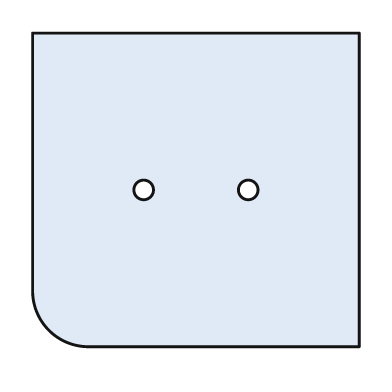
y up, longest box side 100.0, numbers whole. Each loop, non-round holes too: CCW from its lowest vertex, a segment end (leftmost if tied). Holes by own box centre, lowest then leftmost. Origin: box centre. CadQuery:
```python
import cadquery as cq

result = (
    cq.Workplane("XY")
    .moveTo(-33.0, -48.0)
    .lineTo(50.0, -48.0)
    .lineTo(50.0, 48.0)
    .lineTo(-50.0, 48.0)
    .lineTo(-50.0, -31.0)
    .threePointArc((-45.0, -43.0), (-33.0, -48.0))
    .close()
    .moveTo(-16.0, 0.0)
    .circle(3.0)
    .moveTo(16.0, 0.0)
    .circle(3.0)
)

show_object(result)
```